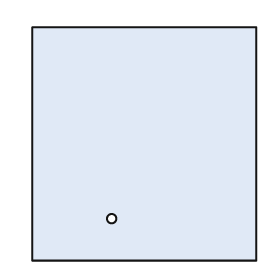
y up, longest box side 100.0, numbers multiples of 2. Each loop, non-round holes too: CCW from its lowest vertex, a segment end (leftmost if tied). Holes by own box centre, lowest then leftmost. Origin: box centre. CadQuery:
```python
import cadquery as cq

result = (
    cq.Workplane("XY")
    .moveTo(-48.0, -50.0)
    .lineTo(48.0, -50.0)
    .lineTo(48.0, 50.0)
    .lineTo(-48.0, 50.0)
    .close()
    .moveTo(-14.0, -32.0)
    .circle(2.0)
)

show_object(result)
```